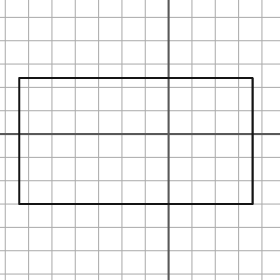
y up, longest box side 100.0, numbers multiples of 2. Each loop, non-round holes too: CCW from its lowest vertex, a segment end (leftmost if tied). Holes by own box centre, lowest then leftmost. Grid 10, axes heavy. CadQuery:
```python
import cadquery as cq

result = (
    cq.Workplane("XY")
    .moveTo(-64.0, -30.0)
    .lineTo(36.0, -30.0)
    .lineTo(36.0, 24.0)
    .lineTo(-64.0, 24.0)
    .close()
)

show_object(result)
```